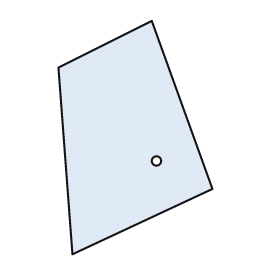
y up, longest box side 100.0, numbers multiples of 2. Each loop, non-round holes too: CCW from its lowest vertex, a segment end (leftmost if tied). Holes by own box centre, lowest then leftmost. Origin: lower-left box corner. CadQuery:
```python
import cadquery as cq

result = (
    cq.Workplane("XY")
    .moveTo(6.0, 0.0)
    .lineTo(66.0, 28.0)
    .lineTo(40.0, 100.0)
    .lineTo(0.0, 80.0)
    .close()
    .moveTo(42.0, 40.0)
    .circle(2.0)
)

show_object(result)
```